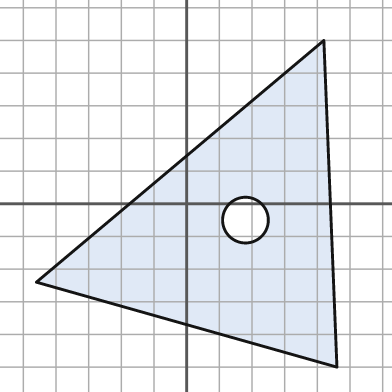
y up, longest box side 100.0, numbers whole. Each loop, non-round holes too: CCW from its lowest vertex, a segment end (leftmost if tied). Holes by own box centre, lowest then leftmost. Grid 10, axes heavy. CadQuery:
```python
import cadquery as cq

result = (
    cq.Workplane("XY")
    .moveTo(46.0, -50.0)
    .lineTo(42.0, 50.0)
    .lineTo(-46.0, -24.0)
    .close()
    .moveTo(18.0, -5.0)
    .circle(7.0)
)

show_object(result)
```